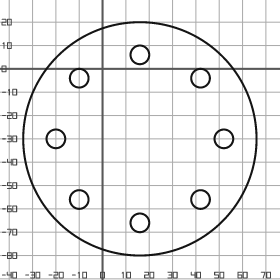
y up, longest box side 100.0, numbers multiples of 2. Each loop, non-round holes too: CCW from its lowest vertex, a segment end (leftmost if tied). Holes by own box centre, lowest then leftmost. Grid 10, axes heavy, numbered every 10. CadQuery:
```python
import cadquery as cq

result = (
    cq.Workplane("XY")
    .moveTo(16.0, -30.0)
    .circle(50.0)
    .moveTo(16.0, -66.0)
    .circle(4.0)
    .moveTo(-10.0, -56.0)
    .circle(4.0)
    .moveTo(42.0, -56.0)
    .circle(4.0)
    .moveTo(-20.0, -30.0)
    .circle(4.0)
    .moveTo(52.0, -30.0)
    .circle(4.0)
    .moveTo(-10.0, -4.0)
    .circle(4.0)
    .moveTo(42.0, -4.0)
    .circle(4.0)
    .moveTo(16.0, 6.0)
    .circle(4.0)
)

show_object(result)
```